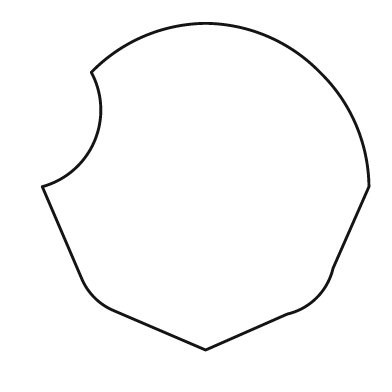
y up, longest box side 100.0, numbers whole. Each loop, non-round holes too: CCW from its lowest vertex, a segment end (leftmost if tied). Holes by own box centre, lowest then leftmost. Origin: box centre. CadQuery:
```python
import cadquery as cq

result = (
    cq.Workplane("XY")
    .moveTo(0.0, -50.0)
    .lineTo(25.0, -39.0)
    .threePointArc((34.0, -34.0), (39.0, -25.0))
    .lineTo(50.0, 0.0)
    .threePointArc((46.0, 19.0), (35.0, 35.0))
    .threePointArc((19.0, 46.0), (0.0, 50.0))
    .threePointArc((-19.0, 46.0), (-35.0, 35.0))
    .threePointArc((-34.0, 14.0), (-50.0, 0.0))
    .lineTo(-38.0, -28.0)
    .threePointArc((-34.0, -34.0), (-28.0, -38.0))
    .close()
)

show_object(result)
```